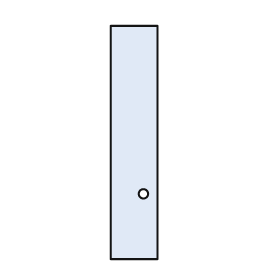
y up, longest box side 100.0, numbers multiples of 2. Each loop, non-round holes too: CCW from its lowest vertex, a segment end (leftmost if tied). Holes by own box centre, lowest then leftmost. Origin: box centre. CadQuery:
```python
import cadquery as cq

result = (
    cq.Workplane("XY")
    .moveTo(-10.0, -50.0)
    .lineTo(10.0, -50.0)
    .lineTo(10.0, 50.0)
    .lineTo(-10.0, 50.0)
    .close()
    .moveTo(4.0, -22.0)
    .circle(2.0)
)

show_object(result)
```